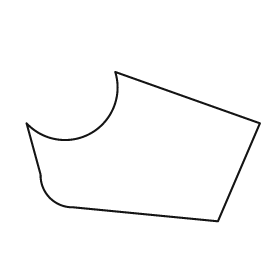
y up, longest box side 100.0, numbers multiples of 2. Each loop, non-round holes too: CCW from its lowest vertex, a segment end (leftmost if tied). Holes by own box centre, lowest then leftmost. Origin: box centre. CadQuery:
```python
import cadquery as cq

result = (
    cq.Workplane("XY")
    .moveTo(32.0, -32.0)
    .lineTo(50.0, 10.0)
    .lineTo(-12.0, 32.0)
    .threePointArc((-22.0, 6.0), (-50.0, 10.0))
    .lineTo(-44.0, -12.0)
    .threePointArc((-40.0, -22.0), (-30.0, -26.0))
    .close()
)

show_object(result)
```